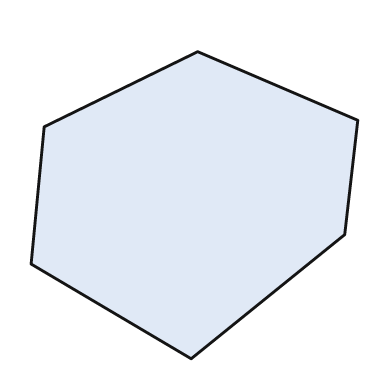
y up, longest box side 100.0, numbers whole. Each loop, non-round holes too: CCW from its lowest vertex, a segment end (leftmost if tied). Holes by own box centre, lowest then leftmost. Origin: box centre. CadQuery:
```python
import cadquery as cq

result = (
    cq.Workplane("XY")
    .moveTo(-1.0, -47.0)
    .lineTo(46.0, -9.0)
    .lineTo(50.0, 26.0)
    .lineTo(1.0, 47.0)
    .lineTo(-46.0, 24.0)
    .lineTo(-50.0, -18.0)
    .close()
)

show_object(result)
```